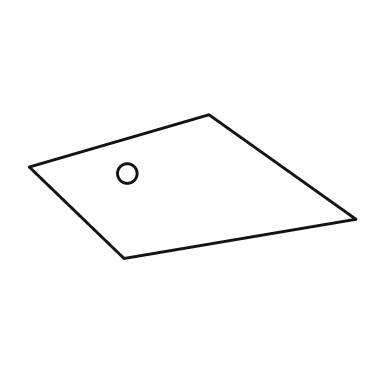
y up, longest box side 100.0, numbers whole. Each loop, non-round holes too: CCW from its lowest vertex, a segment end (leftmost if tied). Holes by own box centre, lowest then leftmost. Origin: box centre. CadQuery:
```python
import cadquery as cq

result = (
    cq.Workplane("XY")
    .moveTo(-21.0, -22.0)
    .lineTo(50.0, -10.0)
    .lineTo(5.0, 22.0)
    .lineTo(-50.0, 6.0)
    .close()
    .moveTo(-20.0, 4.0)
    .circle(3.0)
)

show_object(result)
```